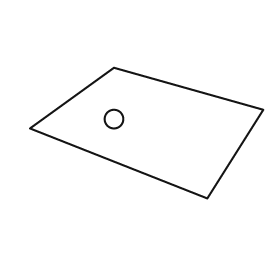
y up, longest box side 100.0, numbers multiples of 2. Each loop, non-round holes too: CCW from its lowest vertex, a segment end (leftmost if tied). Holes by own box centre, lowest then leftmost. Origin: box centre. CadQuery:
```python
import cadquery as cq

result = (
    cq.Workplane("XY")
    .moveTo(26.0, -28.0)
    .lineTo(50.0, 10.0)
    .lineTo(-14.0, 28.0)
    .lineTo(-50.0, 2.0)
    .close()
    .moveTo(-14.0, 6.0)
    .circle(4.0)
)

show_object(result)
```